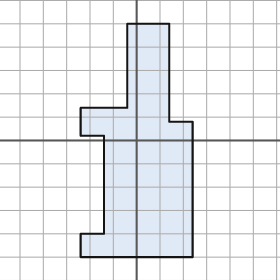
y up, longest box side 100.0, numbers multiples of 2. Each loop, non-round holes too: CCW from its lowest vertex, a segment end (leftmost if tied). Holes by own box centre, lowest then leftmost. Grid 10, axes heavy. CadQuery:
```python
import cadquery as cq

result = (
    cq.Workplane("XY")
    .moveTo(-24.0, -50.0)
    .lineTo(24.0, -50.0)
    .lineTo(24.0, 8.0)
    .lineTo(14.0, 8.0)
    .lineTo(14.0, 50.0)
    .lineTo(-4.0, 50.0)
    .lineTo(-4.0, 14.0)
    .lineTo(-24.0, 14.0)
    .lineTo(-24.0, 2.0)
    .lineTo(-14.0, 2.0)
    .lineTo(-14.0, -40.0)
    .lineTo(-24.0, -40.0)
    .close()
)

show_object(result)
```